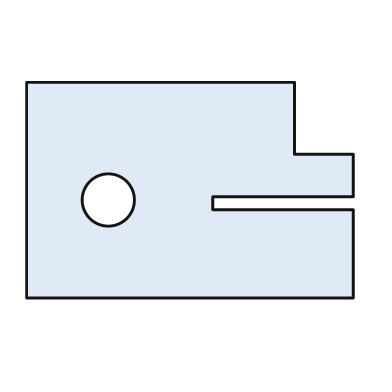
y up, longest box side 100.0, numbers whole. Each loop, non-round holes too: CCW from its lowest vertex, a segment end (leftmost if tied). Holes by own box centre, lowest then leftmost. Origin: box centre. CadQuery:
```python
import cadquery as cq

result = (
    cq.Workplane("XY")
    .moveTo(-50.0, -33.0)
    .lineTo(50.0, -33.0)
    .lineTo(50.0, -6.0)
    .lineTo(7.0, -6.0)
    .lineTo(7.0, -2.0)
    .lineTo(50.0, -2.0)
    .lineTo(50.0, 11.0)
    .lineTo(32.0, 11.0)
    .lineTo(32.0, 33.0)
    .lineTo(-50.0, 33.0)
    .close()
    .moveTo(-25.0, -3.0)
    .circle(8.0)
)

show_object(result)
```